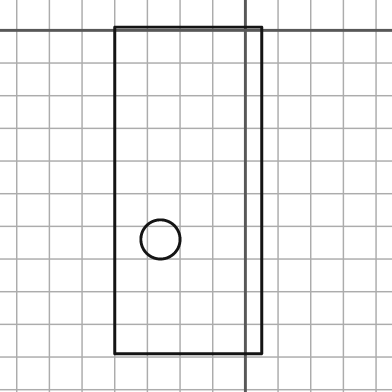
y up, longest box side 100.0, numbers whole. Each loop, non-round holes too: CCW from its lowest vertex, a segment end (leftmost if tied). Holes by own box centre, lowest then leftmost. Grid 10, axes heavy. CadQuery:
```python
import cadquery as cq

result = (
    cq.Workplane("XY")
    .moveTo(-40.0, -99.0)
    .lineTo(5.0, -99.0)
    .lineTo(5.0, 1.0)
    .lineTo(-40.0, 1.0)
    .close()
    .moveTo(-26.0, -64.0)
    .circle(6.0)
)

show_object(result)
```